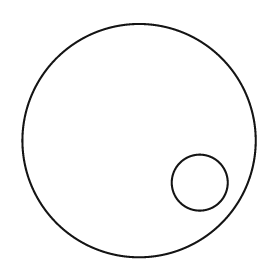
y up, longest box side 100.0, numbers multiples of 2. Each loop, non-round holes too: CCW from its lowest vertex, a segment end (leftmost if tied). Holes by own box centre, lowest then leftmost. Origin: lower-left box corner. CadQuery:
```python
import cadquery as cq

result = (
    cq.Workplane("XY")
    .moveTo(50.0, 50.0)
    .circle(50.0)
    .moveTo(76.0, 32.0)
    .circle(12.0)
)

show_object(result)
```